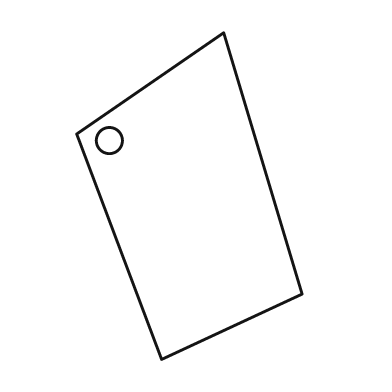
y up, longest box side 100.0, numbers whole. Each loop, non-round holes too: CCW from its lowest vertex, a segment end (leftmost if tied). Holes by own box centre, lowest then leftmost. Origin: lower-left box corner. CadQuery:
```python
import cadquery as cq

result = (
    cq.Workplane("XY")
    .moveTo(26.0, 0.0)
    .lineTo(69.0, 20.0)
    .lineTo(45.0, 100.0)
    .lineTo(0.0, 69.0)
    .close()
    .moveTo(10.0, 67.0)
    .circle(4.0)
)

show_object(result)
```